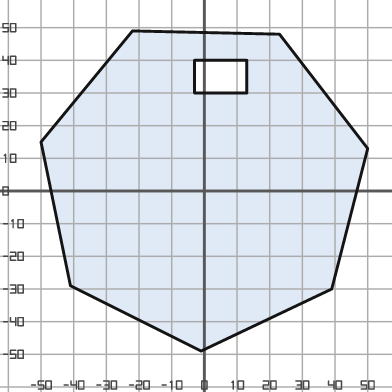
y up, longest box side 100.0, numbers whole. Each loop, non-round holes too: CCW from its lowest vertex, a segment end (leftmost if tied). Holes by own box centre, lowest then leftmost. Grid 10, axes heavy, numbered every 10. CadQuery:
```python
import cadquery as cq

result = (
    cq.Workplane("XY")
    .moveTo(-1.0, -49.0)
    .lineTo(39.0, -30.0)
    .lineTo(50.0, 13.0)
    .lineTo(23.0, 48.0)
    .lineTo(-22.0, 49.0)
    .lineTo(-50.0, 15.0)
    .lineTo(-41.0, -29.0)
    .close()
    .moveTo(-3.0, 30.0)
    .lineTo(13.0, 30.0)
    .lineTo(13.0, 40.0)
    .lineTo(-3.0, 40.0)
    .close()
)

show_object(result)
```